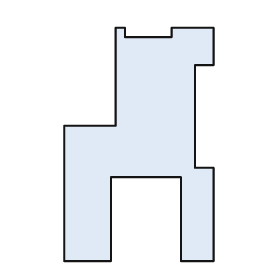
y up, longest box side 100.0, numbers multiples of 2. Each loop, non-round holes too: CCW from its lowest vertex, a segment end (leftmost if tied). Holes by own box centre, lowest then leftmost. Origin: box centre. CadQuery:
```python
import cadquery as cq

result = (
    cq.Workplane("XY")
    .moveTo(-32.0, -50.0)
    .lineTo(-12.0, -50.0)
    .lineTo(-12.0, -14.0)
    .lineTo(18.0, -14.0)
    .lineTo(18.0, -50.0)
    .lineTo(32.0, -50.0)
    .lineTo(32.0, -10.0)
    .lineTo(24.0, -10.0)
    .lineTo(24.0, 34.0)
    .lineTo(32.0, 34.0)
    .lineTo(32.0, 50.0)
    .lineTo(14.0, 50.0)
    .lineTo(14.0, 46.0)
    .lineTo(-6.0, 46.0)
    .lineTo(-6.0, 50.0)
    .lineTo(-10.0, 50.0)
    .lineTo(-10.0, 8.0)
    .lineTo(-32.0, 8.0)
    .close()
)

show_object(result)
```